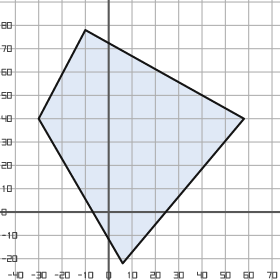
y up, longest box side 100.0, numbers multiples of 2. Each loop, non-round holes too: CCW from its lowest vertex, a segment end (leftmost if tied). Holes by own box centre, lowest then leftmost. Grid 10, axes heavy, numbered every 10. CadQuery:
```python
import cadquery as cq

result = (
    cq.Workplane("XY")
    .moveTo(6.0, -22.0)
    .lineTo(58.0, 40.0)
    .lineTo(-10.0, 78.0)
    .lineTo(-30.0, 40.0)
    .close()
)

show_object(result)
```